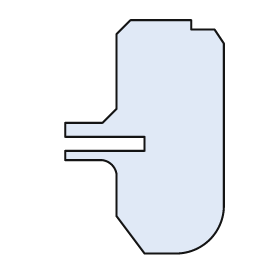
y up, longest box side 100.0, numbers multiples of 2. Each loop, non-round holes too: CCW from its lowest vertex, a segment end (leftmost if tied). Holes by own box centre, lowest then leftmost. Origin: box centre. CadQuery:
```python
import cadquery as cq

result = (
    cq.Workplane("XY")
    .moveTo(0.0, -50.0)
    .lineTo(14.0, -50.0)
    .threePointArc((28.0, -44.0), (34.0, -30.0))
    .lineTo(34.0, 40.0)
    .lineTo(30.0, 46.0)
    .lineTo(20.0, 46.0)
    .lineTo(20.0, 50.0)
    .lineTo(-6.0, 50.0)
    .lineTo(-12.0, 44.0)
    .lineTo(-12.0, 12.0)
    .lineTo(-18.0, 6.0)
    .lineTo(-34.0, 6.0)
    .lineTo(-34.0, 0.0)
    .lineTo(0.0, 0.0)
    .lineTo(0.0, -6.0)
    .lineTo(-34.0, -6.0)
    .lineTo(-34.0, -10.0)
    .lineTo(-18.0, -10.0)
    .threePointArc((-14.0, -12.0), (-12.0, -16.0))
    .lineTo(-12.0, -34.0)
    .close()
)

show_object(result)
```